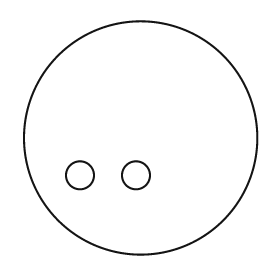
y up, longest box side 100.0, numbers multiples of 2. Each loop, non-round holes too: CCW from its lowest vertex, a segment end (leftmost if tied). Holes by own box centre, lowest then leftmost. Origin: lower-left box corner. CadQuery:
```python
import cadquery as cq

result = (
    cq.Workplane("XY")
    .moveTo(50.0, 50.0)
    .circle(50.0)
    .moveTo(24.0, 34.0)
    .circle(6.0)
    .moveTo(48.0, 34.0)
    .circle(6.0)
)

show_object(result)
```